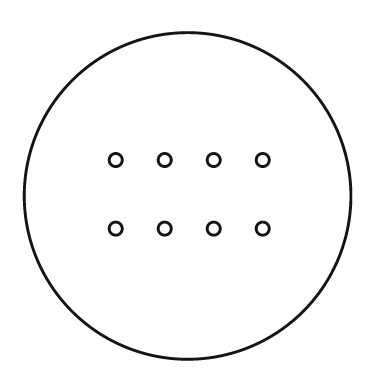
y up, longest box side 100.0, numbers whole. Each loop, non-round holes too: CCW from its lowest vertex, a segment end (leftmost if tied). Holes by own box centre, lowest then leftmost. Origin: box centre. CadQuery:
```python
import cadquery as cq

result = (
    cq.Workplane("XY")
    .moveTo(0.0, 0.0)
    .circle(50.0)
    .moveTo(-22.0, -10.0)
    .circle(2.0)
    .moveTo(-7.0, -10.0)
    .circle(2.0)
    .moveTo(8.0, -10.0)
    .circle(2.0)
    .moveTo(23.0, -10.0)
    .circle(2.0)
    .moveTo(-22.0, 11.0)
    .circle(2.0)
    .moveTo(-7.0, 11.0)
    .circle(2.0)
    .moveTo(8.0, 11.0)
    .circle(2.0)
    .moveTo(23.0, 11.0)
    .circle(2.0)
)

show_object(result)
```